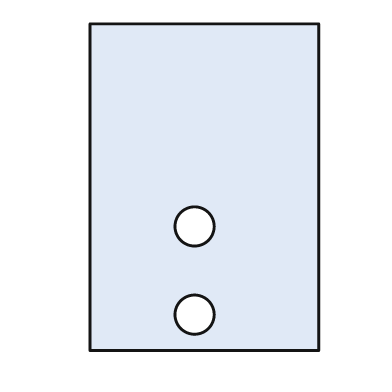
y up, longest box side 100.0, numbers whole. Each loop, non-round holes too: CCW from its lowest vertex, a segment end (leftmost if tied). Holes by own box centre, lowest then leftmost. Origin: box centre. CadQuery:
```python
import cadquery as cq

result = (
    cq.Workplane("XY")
    .moveTo(-35.0, -50.0)
    .lineTo(35.0, -50.0)
    .lineTo(35.0, 50.0)
    .lineTo(-35.0, 50.0)
    .close()
    .moveTo(-3.0, -39.0)
    .circle(6.0)
    .moveTo(-3.0, -12.0)
    .circle(6.0)
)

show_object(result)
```